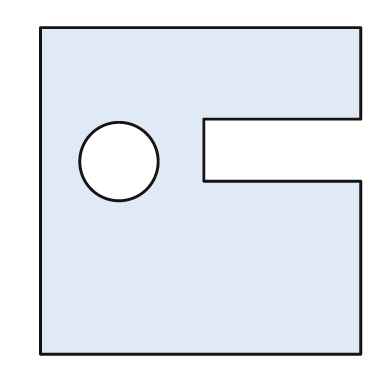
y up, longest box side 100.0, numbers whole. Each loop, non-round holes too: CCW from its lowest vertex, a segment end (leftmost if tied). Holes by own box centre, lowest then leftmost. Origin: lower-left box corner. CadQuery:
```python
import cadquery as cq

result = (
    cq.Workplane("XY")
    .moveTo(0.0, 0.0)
    .lineTo(98.0, 0.0)
    .lineTo(98.0, 53.0)
    .lineTo(50.0, 53.0)
    .lineTo(50.0, 72.0)
    .lineTo(98.0, 72.0)
    .lineTo(98.0, 100.0)
    .lineTo(0.0, 100.0)
    .close()
    .moveTo(24.0, 59.0)
    .circle(12.0)
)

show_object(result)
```